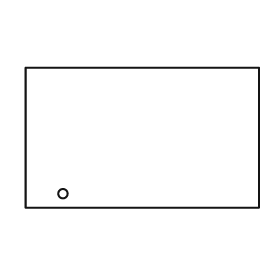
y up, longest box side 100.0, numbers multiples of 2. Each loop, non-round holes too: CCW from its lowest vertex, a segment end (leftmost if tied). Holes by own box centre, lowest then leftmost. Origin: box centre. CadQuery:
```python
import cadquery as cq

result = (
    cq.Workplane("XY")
    .moveTo(-50.0, -30.0)
    .lineTo(50.0, -30.0)
    .lineTo(50.0, 30.0)
    .lineTo(-50.0, 30.0)
    .close()
    .moveTo(-34.0, -24.0)
    .circle(2.0)
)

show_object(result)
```